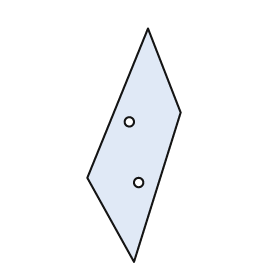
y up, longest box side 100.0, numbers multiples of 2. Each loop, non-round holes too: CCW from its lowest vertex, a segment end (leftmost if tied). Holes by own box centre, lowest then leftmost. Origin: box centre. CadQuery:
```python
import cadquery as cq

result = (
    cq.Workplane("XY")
    .moveTo(0.0, -50.0)
    .lineTo(20.0, 14.0)
    .lineTo(6.0, 50.0)
    .lineTo(-20.0, -14.0)
    .close()
    .moveTo(2.0, -16.0)
    .circle(2.0)
    .moveTo(-2.0, 10.0)
    .circle(2.0)
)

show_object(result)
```